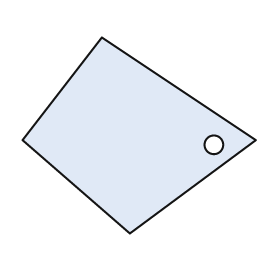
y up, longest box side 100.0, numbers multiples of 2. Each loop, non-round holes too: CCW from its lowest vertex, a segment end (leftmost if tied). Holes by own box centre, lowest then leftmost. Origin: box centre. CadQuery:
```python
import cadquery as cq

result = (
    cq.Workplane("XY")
    .moveTo(-4.0, -42.0)
    .lineTo(50.0, -2.0)
    .lineTo(-16.0, 42.0)
    .lineTo(-50.0, -2.0)
    .close()
    .moveTo(32.0, -4.0)
    .circle(4.0)
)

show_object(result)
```